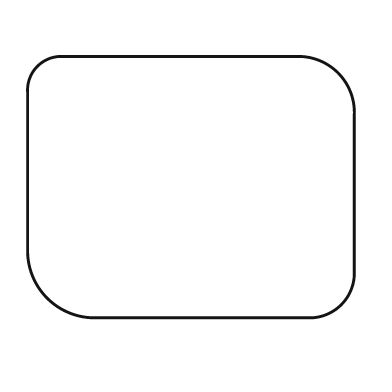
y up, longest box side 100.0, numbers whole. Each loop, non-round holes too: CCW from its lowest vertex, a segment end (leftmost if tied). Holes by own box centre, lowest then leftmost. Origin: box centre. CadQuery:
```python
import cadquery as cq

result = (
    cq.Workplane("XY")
    .moveTo(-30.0, -40.0)
    .lineTo(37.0, -40.0)
    .threePointArc((46.0, -36.0), (50.0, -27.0))
    .lineTo(50.0, 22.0)
    .threePointArc((45.0, 35.0), (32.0, 40.0))
    .lineTo(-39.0, 40.0)
    .threePointArc((-47.0, 37.0), (-50.0, 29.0))
    .lineTo(-50.0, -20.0)
    .threePointArc((-44.0, -34.0), (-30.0, -40.0))
    .close()
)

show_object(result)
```